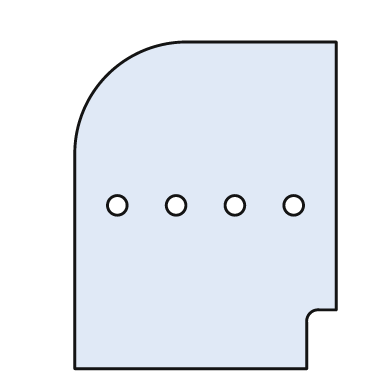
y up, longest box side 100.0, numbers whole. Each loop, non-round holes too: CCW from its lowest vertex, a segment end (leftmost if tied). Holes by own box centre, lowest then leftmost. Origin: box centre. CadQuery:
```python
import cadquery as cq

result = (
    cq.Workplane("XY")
    .moveTo(-40.0, -50.0)
    .lineTo(31.0, -50.0)
    .lineTo(31.0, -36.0)
    .threePointArc((32.0, -33.0), (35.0, -32.0))
    .lineTo(40.0, -32.0)
    .lineTo(40.0, 50.0)
    .lineTo(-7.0, 50.0)
    .threePointArc((-30.0, 40.0), (-40.0, 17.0))
    .close()
    .moveTo(-27.0, 0.0)
    .circle(3.0)
    .moveTo(-9.0, 0.0)
    .circle(3.0)
    .moveTo(9.0, 0.0)
    .circle(3.0)
    .moveTo(27.0, 0.0)
    .circle(3.0)
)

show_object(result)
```